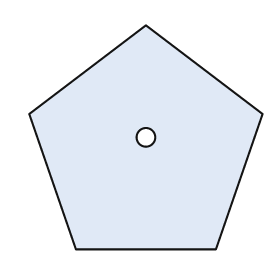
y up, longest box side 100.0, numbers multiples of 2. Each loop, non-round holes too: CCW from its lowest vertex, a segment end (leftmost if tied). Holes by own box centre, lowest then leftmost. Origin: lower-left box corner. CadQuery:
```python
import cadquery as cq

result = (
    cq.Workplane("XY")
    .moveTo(20.0, 0.0)
    .lineTo(80.0, 0.0)
    .lineTo(100.0, 58.0)
    .lineTo(50.0, 96.0)
    .lineTo(0.0, 58.0)
    .close()
    .moveTo(50.0, 48.0)
    .circle(4.0)
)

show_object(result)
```